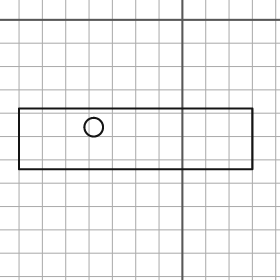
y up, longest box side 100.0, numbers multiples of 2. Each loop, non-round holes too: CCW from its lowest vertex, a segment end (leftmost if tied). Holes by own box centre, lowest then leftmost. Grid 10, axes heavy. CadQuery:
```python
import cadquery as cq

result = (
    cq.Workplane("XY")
    .moveTo(-70.0, -64.0)
    .lineTo(30.0, -64.0)
    .lineTo(30.0, -38.0)
    .lineTo(-70.0, -38.0)
    .close()
    .moveTo(-38.0, -46.0)
    .circle(4.0)
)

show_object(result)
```